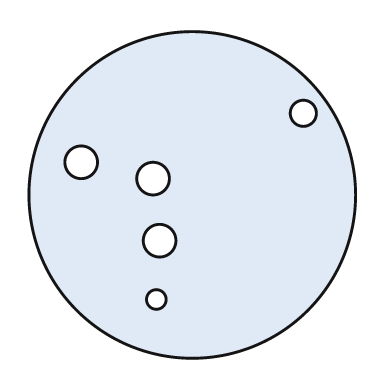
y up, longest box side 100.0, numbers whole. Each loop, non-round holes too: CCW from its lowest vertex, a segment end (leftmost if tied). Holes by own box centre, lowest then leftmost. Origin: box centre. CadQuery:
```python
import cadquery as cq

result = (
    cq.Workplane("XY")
    .moveTo(0.0, 0.0)
    .circle(50.0)
    .moveTo(-11.0, -32.0)
    .circle(3.0)
    .moveTo(-10.0, -14.0)
    .circle(5.0)
    .moveTo(-12.0, 5.0)
    .circle(5.0)
    .moveTo(-34.0, 10.0)
    .circle(5.0)
    .moveTo(34.0, 25.0)
    .circle(4.0)
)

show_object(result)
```